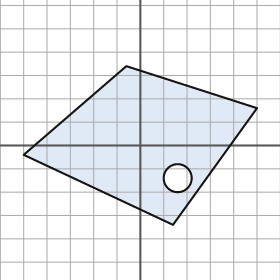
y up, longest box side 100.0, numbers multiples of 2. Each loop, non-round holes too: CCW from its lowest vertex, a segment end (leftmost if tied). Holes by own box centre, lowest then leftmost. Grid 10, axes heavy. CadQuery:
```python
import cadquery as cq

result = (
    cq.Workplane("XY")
    .moveTo(14.0, -34.0)
    .lineTo(50.0, 16.0)
    .lineTo(-6.0, 34.0)
    .lineTo(-50.0, -4.0)
    .close()
    .moveTo(16.0, -14.0)
    .circle(6.0)
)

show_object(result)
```